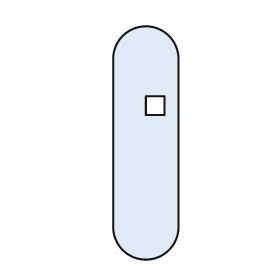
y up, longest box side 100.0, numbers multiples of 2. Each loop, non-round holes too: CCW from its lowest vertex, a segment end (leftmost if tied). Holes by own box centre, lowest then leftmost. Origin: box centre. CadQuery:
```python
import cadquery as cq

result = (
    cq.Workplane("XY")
    .moveTo(-14.0, -36.0)
    .threePointArc((0.0, -50.0), (14.0, -36.0))
    .lineTo(14.0, 36.0)
    .threePointArc((0.0, 50.0), (-14.0, 36.0))
    .close()
    .moveTo(0.0, 12.0)
    .lineTo(8.0, 12.0)
    .lineTo(8.0, 20.0)
    .lineTo(0.0, 20.0)
    .close()
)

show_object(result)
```